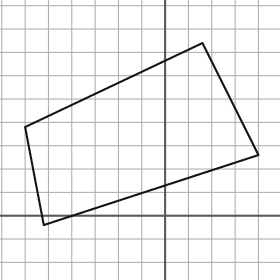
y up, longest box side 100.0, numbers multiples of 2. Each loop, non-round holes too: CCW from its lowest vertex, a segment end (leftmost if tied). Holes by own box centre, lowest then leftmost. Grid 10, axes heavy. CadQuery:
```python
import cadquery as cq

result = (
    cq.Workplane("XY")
    .moveTo(-52.0, -4.0)
    .lineTo(40.0, 26.0)
    .lineTo(16.0, 74.0)
    .lineTo(-60.0, 38.0)
    .close()
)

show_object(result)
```